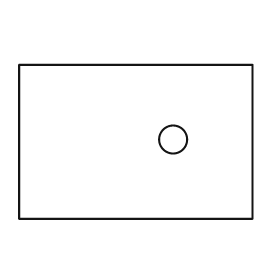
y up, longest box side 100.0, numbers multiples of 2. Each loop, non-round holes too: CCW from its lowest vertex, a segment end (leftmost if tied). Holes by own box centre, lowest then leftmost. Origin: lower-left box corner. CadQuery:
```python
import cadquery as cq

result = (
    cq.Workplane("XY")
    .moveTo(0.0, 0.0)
    .lineTo(100.0, 0.0)
    .lineTo(100.0, 66.0)
    .lineTo(0.0, 66.0)
    .close()
    .moveTo(66.0, 34.0)
    .circle(6.0)
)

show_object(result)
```